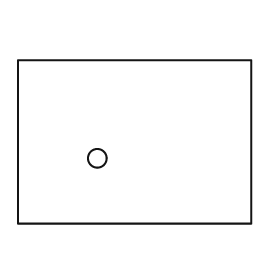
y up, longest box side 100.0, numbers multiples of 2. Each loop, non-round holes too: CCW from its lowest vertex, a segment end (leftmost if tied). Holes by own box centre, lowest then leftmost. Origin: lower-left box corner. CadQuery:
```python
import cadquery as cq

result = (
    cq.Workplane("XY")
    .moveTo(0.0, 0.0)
    .lineTo(100.0, 0.0)
    .lineTo(100.0, 70.0)
    .lineTo(0.0, 70.0)
    .close()
    .moveTo(34.0, 28.0)
    .circle(4.0)
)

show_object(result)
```